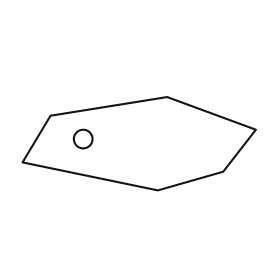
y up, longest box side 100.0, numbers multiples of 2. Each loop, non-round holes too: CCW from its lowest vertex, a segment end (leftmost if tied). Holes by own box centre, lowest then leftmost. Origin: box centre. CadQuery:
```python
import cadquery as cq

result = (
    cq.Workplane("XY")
    .moveTo(8.0, -20.0)
    .lineTo(36.0, -12.0)
    .lineTo(50.0, 6.0)
    .lineTo(12.0, 20.0)
    .lineTo(-38.0, 12.0)
    .lineTo(-50.0, -8.0)
    .close()
    .moveTo(-24.0, 2.0)
    .circle(4.0)
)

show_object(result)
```